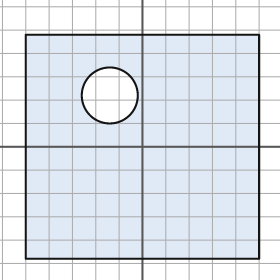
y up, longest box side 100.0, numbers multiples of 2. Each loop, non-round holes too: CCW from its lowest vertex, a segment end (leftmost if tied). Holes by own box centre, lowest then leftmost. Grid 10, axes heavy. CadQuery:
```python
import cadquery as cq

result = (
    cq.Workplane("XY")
    .moveTo(-50.0, -48.0)
    .lineTo(50.0, -48.0)
    .lineTo(50.0, 48.0)
    .lineTo(-50.0, 48.0)
    .close()
    .moveTo(-14.0, 22.0)
    .circle(12.0)
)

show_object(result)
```